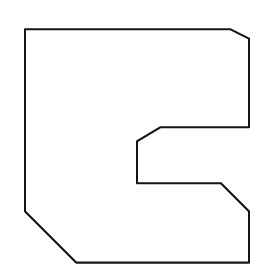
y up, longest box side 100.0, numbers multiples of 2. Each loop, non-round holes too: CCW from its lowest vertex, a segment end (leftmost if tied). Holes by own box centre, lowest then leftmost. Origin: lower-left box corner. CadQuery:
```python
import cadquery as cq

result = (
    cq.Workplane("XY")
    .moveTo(22.0, 0.0)
    .lineTo(96.0, 0.0)
    .lineTo(96.0, 22.0)
    .lineTo(84.0, 34.0)
    .lineTo(48.0, 34.0)
    .lineTo(48.0, 52.0)
    .lineTo(58.0, 58.0)
    .lineTo(96.0, 58.0)
    .lineTo(96.0, 96.0)
    .lineTo(88.0, 100.0)
    .lineTo(0.0, 100.0)
    .lineTo(0.0, 22.0)
    .close()
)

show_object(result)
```